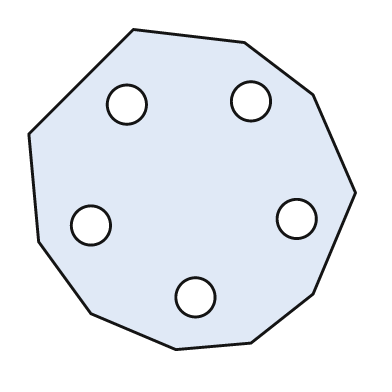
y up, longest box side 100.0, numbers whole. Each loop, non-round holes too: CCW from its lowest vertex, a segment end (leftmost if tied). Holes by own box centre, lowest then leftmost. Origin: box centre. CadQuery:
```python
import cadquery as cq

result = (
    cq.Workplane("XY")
    .moveTo(-5.0, -49.0)
    .lineTo(18.0, -47.0)
    .lineTo(37.0, -32.0)
    .lineTo(50.0, -1.0)
    .lineTo(37.0, 29.0)
    .lineTo(16.0, 45.0)
    .lineTo(-18.0, 49.0)
    .lineTo(-50.0, 17.0)
    .lineTo(-47.0, -16.0)
    .lineTo(-31.0, -38.0)
    .close()
    .moveTo(1.0, -33.0)
    .circle(6.0)
    .moveTo(-31.0, -11.0)
    .circle(6.0)
    .moveTo(32.0, -9.0)
    .circle(6.0)
    .moveTo(-20.0, 26.0)
    .circle(6.0)
    .moveTo(18.0, 27.0)
    .circle(6.0)
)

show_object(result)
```